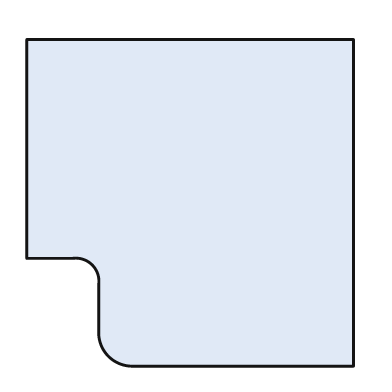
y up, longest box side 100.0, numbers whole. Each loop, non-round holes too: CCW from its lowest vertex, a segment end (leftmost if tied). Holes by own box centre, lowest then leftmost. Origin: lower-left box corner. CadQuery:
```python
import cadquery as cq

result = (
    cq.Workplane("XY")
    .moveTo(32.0, 0.0)
    .lineTo(100.0, 0.0)
    .lineTo(100.0, 100.0)
    .lineTo(0.0, 100.0)
    .lineTo(0.0, 33.0)
    .lineTo(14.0, 33.0)
    .threePointArc((20.0, 31.0), (22.0, 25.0))
    .lineTo(22.0, 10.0)
    .threePointArc((25.0, 3.0), (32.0, 0.0))
    .close()
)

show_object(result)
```